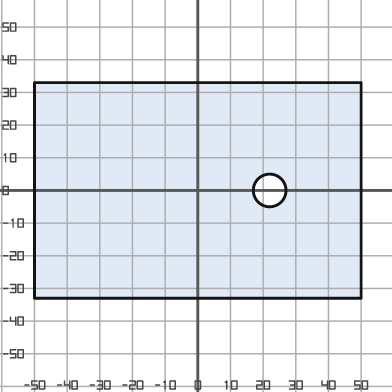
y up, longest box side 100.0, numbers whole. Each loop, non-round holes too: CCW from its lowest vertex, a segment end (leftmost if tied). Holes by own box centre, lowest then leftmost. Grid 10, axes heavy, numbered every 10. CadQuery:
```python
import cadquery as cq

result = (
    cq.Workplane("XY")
    .moveTo(-50.0, -33.0)
    .lineTo(50.0, -33.0)
    .lineTo(50.0, 33.0)
    .lineTo(-50.0, 33.0)
    .close()
    .moveTo(22.0, 0.0)
    .circle(5.0)
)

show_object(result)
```